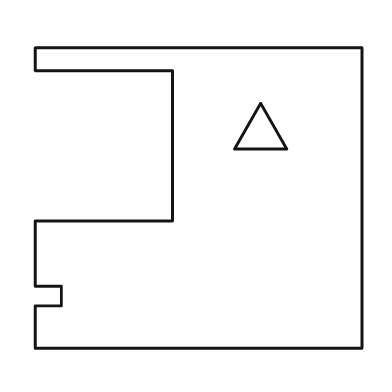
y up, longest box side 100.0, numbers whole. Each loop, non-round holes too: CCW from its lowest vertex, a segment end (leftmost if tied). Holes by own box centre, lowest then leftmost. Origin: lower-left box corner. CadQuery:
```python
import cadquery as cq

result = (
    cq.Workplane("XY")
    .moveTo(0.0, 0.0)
    .lineTo(100.0, 0.0)
    .lineTo(100.0, 92.0)
    .lineTo(0.0, 92.0)
    .lineTo(0.0, 85.0)
    .lineTo(42.0, 85.0)
    .lineTo(42.0, 39.0)
    .lineTo(0.0, 39.0)
    .lineTo(0.0, 19.0)
    .lineTo(8.0, 19.0)
    .lineTo(8.0, 13.0)
    .lineTo(0.0, 13.0)
    .close()
    .moveTo(61.0, 61.0)
    .lineTo(77.0, 61.0)
    .lineTo(69.0, 75.0)
    .close()
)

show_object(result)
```